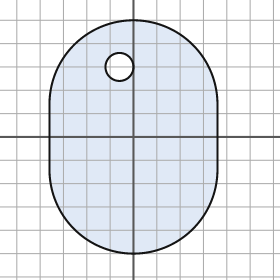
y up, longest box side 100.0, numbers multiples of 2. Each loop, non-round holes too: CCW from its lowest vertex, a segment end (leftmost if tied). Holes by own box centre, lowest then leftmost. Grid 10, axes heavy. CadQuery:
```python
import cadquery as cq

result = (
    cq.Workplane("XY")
    .moveTo(-36.0, -14.0)
    .threePointArc((0.0, -50.0), (36.0, -14.0))
    .lineTo(36.0, 14.0)
    .threePointArc((0.0, 50.0), (-36.0, 14.0))
    .close()
    .moveTo(-6.0, 30.0)
    .circle(6.0)
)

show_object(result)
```